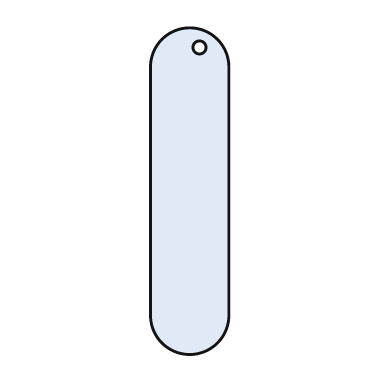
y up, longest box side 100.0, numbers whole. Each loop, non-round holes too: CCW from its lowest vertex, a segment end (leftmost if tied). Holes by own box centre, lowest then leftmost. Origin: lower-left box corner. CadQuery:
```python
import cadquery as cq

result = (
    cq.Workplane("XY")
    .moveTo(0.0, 12.0)
    .threePointArc((12.0, 0.0), (24.0, 12.0))
    .lineTo(24.0, 88.0)
    .threePointArc((12.0, 100.0), (0.0, 88.0))
    .close()
    .moveTo(15.0, 94.0)
    .circle(2.0)
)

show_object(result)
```